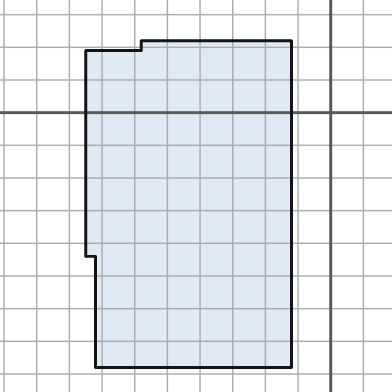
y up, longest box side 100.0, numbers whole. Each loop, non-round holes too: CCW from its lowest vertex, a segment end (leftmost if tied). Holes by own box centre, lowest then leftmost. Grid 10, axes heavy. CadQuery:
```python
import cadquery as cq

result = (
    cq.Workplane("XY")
    .moveTo(-72.0, -78.0)
    .lineTo(-12.0, -78.0)
    .lineTo(-12.0, 22.0)
    .lineTo(-58.0, 22.0)
    .lineTo(-58.0, 19.0)
    .lineTo(-75.0, 19.0)
    .lineTo(-75.0, -44.0)
    .lineTo(-72.0, -44.0)
    .close()
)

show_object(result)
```